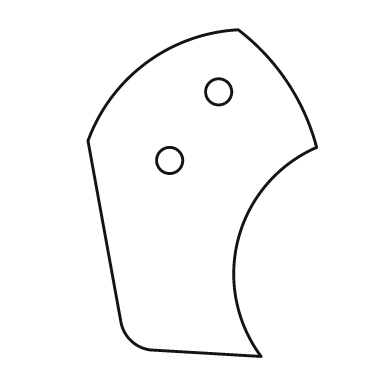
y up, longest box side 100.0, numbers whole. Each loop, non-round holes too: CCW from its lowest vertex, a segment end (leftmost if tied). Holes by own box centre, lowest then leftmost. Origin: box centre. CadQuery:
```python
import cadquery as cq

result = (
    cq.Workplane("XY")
    .moveTo(18.0, -50.0)
    .threePointArc((11.0, -14.0), (35.0, 14.0))
    .threePointArc((26.0, 34.0), (11.0, 50.0))
    .threePointArc((-17.0, 40.0), (-35.0, 16.0))
    .lineTo(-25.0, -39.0)
    .threePointArc((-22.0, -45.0), (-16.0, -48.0))
    .close()
    .moveTo(-10.0, 10.0)
    .circle(4.0)
    .moveTo(5.0, 31.0)
    .circle(4.0)
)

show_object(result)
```